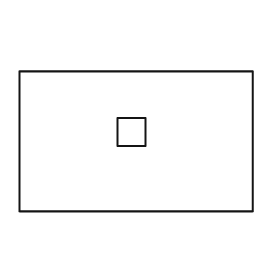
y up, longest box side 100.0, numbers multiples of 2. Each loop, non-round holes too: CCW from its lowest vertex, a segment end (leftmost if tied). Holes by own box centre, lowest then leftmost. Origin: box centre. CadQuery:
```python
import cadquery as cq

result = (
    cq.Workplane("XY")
    .moveTo(-50.0, -30.0)
    .lineTo(50.0, -30.0)
    .lineTo(50.0, 30.0)
    .lineTo(-50.0, 30.0)
    .close()
    .moveTo(-8.0, -2.0)
    .lineTo(4.0, -2.0)
    .lineTo(4.0, 10.0)
    .lineTo(-8.0, 10.0)
    .close()
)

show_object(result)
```